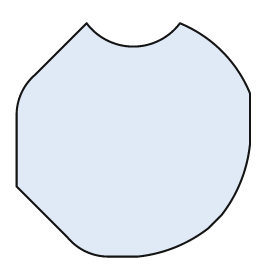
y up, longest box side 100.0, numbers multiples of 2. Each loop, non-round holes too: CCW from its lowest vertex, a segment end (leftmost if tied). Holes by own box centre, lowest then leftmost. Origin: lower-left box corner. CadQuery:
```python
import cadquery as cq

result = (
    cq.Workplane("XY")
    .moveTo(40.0, 0.0)
    .lineTo(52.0, 0.0)
    .threePointArc((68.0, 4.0), (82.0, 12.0))
    .lineTo(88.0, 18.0)
    .threePointArc((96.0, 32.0), (100.0, 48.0))
    .lineTo(100.0, 70.0)
    .threePointArc((88.0, 88.0), (70.0, 100.0))
    .threePointArc((50.0, 90.0), (30.0, 100.0))
    .lineTo(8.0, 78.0)
    .threePointArc((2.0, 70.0), (0.0, 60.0))
    .lineTo(0.0, 30.0)
    .lineTo(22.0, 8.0)
    .threePointArc((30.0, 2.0), (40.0, 0.0))
    .close()
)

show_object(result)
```